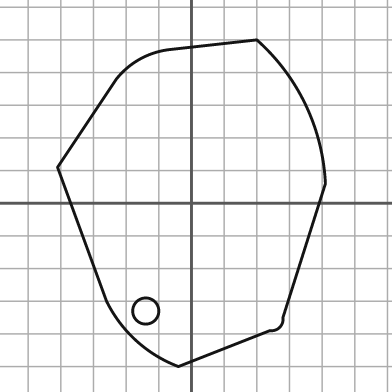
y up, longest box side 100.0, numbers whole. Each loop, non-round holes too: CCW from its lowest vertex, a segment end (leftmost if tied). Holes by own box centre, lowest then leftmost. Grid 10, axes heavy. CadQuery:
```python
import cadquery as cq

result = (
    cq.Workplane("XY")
    .moveTo(-4.0, -50.0)
    .lineTo(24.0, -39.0)
    .threePointArc((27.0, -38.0), (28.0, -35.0))
    .lineTo(41.0, 6.0)
    .threePointArc((35.0, 30.0), (20.0, 50.0))
    .lineTo(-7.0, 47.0)
    .threePointArc((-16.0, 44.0), (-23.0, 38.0))
    .lineTo(-41.0, 11.0)
    .lineTo(-26.0, -30.0)
    .threePointArc((-17.0, -42.0), (-4.0, -50.0))
    .close()
    .moveTo(-14.0, -33.0)
    .circle(4.0)
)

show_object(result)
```